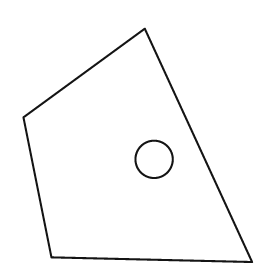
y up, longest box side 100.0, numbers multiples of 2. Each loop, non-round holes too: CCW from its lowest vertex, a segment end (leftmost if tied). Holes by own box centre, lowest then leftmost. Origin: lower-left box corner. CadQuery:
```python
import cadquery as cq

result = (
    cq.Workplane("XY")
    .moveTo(98.0, 0.0)
    .lineTo(52.0, 100.0)
    .lineTo(0.0, 62.0)
    .lineTo(12.0, 2.0)
    .close()
    .moveTo(56.0, 44.0)
    .circle(8.0)
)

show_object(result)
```